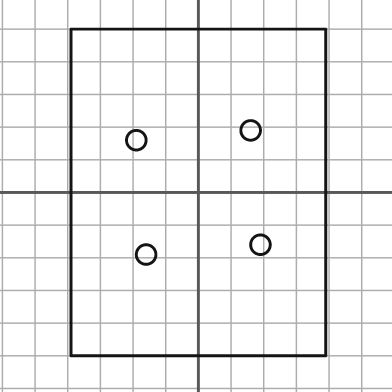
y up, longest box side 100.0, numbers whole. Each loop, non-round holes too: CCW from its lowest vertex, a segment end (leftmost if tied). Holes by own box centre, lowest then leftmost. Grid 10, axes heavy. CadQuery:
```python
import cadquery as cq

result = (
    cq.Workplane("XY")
    .moveTo(-39.0, -50.0)
    .lineTo(39.0, -50.0)
    .lineTo(39.0, 50.0)
    .lineTo(-39.0, 50.0)
    .close()
    .moveTo(-16.0, -19.0)
    .circle(3.0)
    .moveTo(19.0, -16.0)
    .circle(3.0)
    .moveTo(-19.0, 16.0)
    .circle(3.0)
    .moveTo(16.0, 19.0)
    .circle(3.0)
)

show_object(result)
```